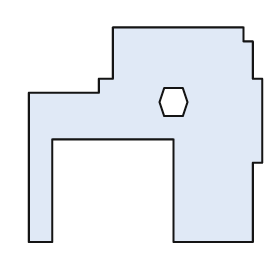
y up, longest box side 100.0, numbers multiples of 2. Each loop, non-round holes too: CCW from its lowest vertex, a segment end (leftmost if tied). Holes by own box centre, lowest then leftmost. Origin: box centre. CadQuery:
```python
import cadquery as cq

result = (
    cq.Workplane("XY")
    .moveTo(-50.0, -46.0)
    .lineTo(-40.0, -46.0)
    .lineTo(-40.0, -2.0)
    .lineTo(12.0, -2.0)
    .lineTo(12.0, -46.0)
    .lineTo(46.0, -46.0)
    .lineTo(46.0, -12.0)
    .lineTo(50.0, -12.0)
    .lineTo(50.0, 24.0)
    .lineTo(46.0, 24.0)
    .lineTo(46.0, 40.0)
    .lineTo(42.0, 40.0)
    .lineTo(42.0, 46.0)
    .lineTo(-14.0, 46.0)
    .lineTo(-14.0, 24.0)
    .lineTo(-20.0, 24.0)
    .lineTo(-20.0, 18.0)
    .lineTo(-50.0, 18.0)
    .close()
    .moveTo(8.0, 8.0)
    .lineTo(16.0, 8.0)
    .lineTo(18.0, 14.0)
    .lineTo(16.0, 20.0)
    .lineTo(8.0, 20.0)
    .lineTo(6.0, 14.0)
    .close()
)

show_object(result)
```